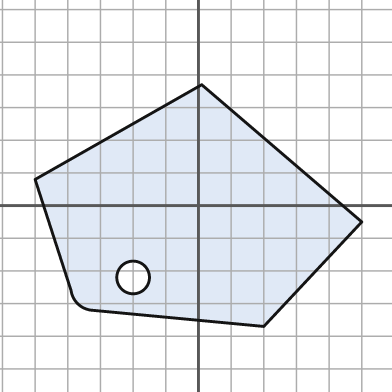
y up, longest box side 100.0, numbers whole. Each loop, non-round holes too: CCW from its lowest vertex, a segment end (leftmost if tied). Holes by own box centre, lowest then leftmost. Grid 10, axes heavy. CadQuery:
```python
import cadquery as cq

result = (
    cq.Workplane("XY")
    .moveTo(20.0, -37.0)
    .lineTo(50.0, -5.0)
    .lineTo(1.0, 37.0)
    .lineTo(-50.0, 8.0)
    .lineTo(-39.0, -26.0)
    .threePointArc((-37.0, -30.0), (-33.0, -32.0))
    .close()
    .moveTo(-20.0, -22.0)
    .circle(5.0)
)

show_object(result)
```